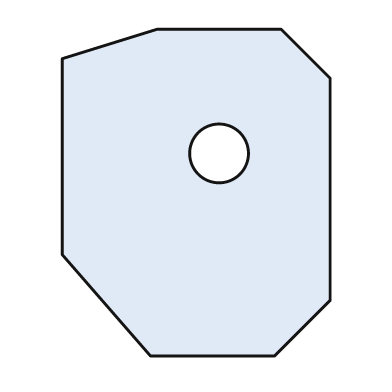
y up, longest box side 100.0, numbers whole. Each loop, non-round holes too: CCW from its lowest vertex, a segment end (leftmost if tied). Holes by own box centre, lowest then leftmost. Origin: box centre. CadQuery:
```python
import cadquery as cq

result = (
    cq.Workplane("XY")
    .moveTo(-14.0, -50.0)
    .lineTo(24.0, -50.0)
    .lineTo(41.0, -33.0)
    .lineTo(41.0, 35.0)
    .lineTo(26.0, 50.0)
    .lineTo(-12.0, 50.0)
    .lineTo(-41.0, 41.0)
    .lineTo(-41.0, -19.0)
    .close()
    .moveTo(7.0, 12.0)
    .circle(9.0)
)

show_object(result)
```